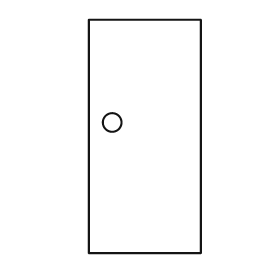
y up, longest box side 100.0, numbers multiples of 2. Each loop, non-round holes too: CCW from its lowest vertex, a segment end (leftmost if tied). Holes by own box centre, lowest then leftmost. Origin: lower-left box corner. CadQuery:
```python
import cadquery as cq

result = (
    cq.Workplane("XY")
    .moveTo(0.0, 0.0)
    .lineTo(48.0, 0.0)
    .lineTo(48.0, 100.0)
    .lineTo(0.0, 100.0)
    .close()
    .moveTo(10.0, 56.0)
    .circle(4.0)
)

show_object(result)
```